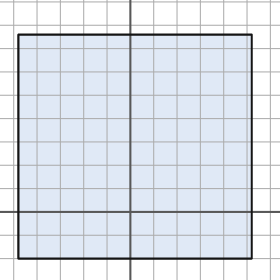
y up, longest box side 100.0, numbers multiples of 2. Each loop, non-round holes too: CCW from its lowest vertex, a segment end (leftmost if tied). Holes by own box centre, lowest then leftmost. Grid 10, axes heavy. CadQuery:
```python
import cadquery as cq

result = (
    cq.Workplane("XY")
    .moveTo(-48.0, -20.0)
    .lineTo(52.0, -20.0)
    .lineTo(52.0, 76.0)
    .lineTo(-48.0, 76.0)
    .close()
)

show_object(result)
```